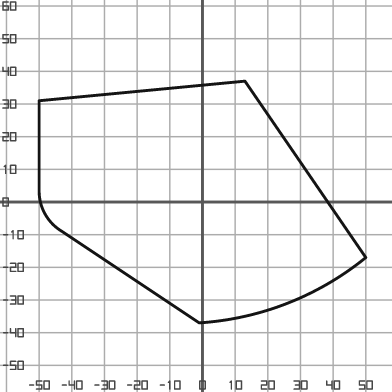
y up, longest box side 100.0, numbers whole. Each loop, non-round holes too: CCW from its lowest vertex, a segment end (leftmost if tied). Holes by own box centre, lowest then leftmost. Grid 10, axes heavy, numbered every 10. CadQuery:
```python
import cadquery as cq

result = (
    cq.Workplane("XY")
    .moveTo(-1.0, -37.0)
    .threePointArc((26.0, -31.0), (50.0, -17.0))
    .lineTo(13.0, 37.0)
    .lineTo(-50.0, 31.0)
    .lineTo(-50.0, 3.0)
    .threePointArc((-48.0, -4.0), (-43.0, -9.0))
    .close()
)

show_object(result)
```